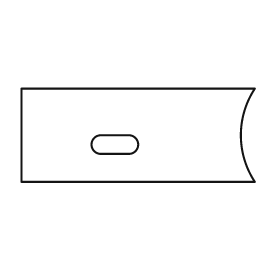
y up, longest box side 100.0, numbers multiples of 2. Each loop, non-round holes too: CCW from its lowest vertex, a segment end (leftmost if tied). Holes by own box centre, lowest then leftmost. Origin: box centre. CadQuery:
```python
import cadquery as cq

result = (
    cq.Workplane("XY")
    .moveTo(-50.0, -20.0)
    .lineTo(50.0, -20.0)
    .threePointArc((44.0, 0.0), (50.0, 20.0))
    .lineTo(-50.0, 20.0)
    .close()
    .moveTo(-16.0, -8.0)
    .lineTo(-4.0, -8.0)
    .threePointArc((0.0, -4.0), (-4.0, 0.0))
    .lineTo(-16.0, 0.0)
    .threePointArc((-20.0, -4.0), (-16.0, -8.0))
    .close()
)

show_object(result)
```